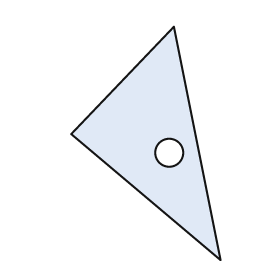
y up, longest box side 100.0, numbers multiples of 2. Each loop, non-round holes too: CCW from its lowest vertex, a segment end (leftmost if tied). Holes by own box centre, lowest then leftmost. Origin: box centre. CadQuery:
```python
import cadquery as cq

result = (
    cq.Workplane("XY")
    .moveTo(32.0, -50.0)
    .lineTo(12.0, 50.0)
    .lineTo(-32.0, 4.0)
    .close()
    .moveTo(10.0, -4.0)
    .circle(6.0)
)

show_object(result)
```